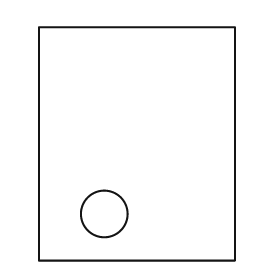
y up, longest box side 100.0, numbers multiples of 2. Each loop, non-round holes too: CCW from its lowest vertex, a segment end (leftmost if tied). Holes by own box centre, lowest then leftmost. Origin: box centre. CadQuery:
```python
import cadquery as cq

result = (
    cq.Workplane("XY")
    .moveTo(-42.0, -50.0)
    .lineTo(42.0, -50.0)
    .lineTo(42.0, 50.0)
    .lineTo(-42.0, 50.0)
    .close()
    .moveTo(-14.0, -30.0)
    .circle(10.0)
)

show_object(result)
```